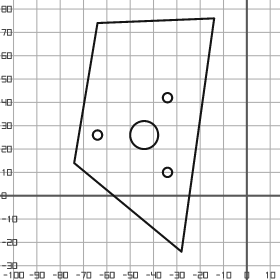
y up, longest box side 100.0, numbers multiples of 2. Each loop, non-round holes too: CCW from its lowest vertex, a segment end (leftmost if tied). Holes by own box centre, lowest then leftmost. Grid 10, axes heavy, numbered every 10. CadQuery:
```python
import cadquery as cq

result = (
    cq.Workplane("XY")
    .moveTo(-28.0, -24.0)
    .lineTo(-14.0, 76.0)
    .lineTo(-64.0, 74.0)
    .lineTo(-74.0, 14.0)
    .close()
    .moveTo(-34.0, 10.0)
    .circle(2.0)
    .moveTo(-64.0, 26.0)
    .circle(2.0)
    .moveTo(-44.0, 26.0)
    .circle(6.0)
    .moveTo(-34.0, 42.0)
    .circle(2.0)
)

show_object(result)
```